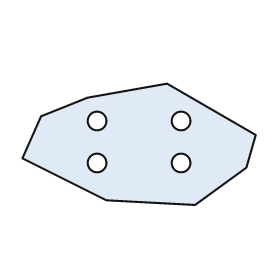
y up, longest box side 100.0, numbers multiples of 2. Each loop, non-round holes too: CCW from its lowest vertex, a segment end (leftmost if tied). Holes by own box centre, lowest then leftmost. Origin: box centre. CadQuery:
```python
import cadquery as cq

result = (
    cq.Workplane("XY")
    .moveTo(24.0, -26.0)
    .lineTo(46.0, -10.0)
    .lineTo(50.0, 4.0)
    .lineTo(12.0, 26.0)
    .lineTo(-22.0, 20.0)
    .lineTo(-42.0, 12.0)
    .lineTo(-50.0, -6.0)
    .lineTo(-14.0, -24.0)
    .close()
    .moveTo(-18.0, -8.0)
    .circle(4.0)
    .moveTo(18.0, -8.0)
    .circle(4.0)
    .moveTo(-18.0, 10.0)
    .circle(4.0)
    .moveTo(18.0, 10.0)
    .circle(4.0)
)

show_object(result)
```